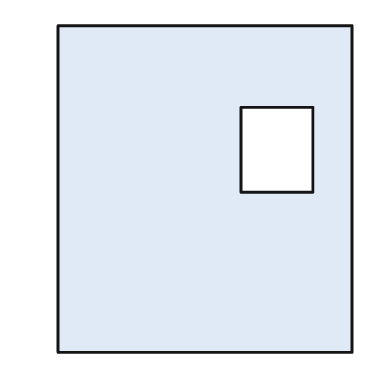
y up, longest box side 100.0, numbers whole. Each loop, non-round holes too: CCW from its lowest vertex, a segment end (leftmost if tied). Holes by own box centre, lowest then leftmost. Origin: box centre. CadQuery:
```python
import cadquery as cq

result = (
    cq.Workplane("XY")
    .moveTo(-45.0, -50.0)
    .lineTo(45.0, -50.0)
    .lineTo(45.0, 50.0)
    .lineTo(-45.0, 50.0)
    .close()
    .moveTo(11.0, -1.0)
    .lineTo(33.0, -1.0)
    .lineTo(33.0, 25.0)
    .lineTo(11.0, 25.0)
    .close()
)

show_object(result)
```